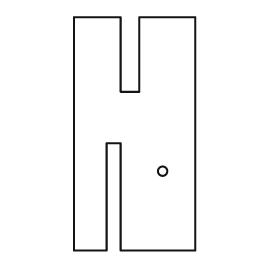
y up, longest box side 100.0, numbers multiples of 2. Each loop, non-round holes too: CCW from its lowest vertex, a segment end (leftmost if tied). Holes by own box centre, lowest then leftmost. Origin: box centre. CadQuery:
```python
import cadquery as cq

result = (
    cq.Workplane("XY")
    .moveTo(-26.0, -50.0)
    .lineTo(-12.0, -50.0)
    .lineTo(-12.0, -4.0)
    .lineTo(-6.0, -4.0)
    .lineTo(-6.0, -50.0)
    .lineTo(26.0, -50.0)
    .lineTo(26.0, 50.0)
    .lineTo(2.0, 50.0)
    .lineTo(2.0, 18.0)
    .lineTo(-6.0, 18.0)
    .lineTo(-6.0, 50.0)
    .lineTo(-26.0, 50.0)
    .close()
    .moveTo(12.0, -16.0)
    .circle(2.0)
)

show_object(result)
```